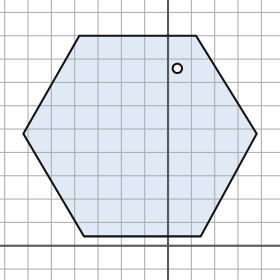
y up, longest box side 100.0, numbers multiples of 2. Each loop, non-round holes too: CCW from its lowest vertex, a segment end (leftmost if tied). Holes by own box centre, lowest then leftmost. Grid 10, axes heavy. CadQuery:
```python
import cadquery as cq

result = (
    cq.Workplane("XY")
    .moveTo(-36.0, 4.0)
    .lineTo(14.0, 4.0)
    .lineTo(38.0, 48.0)
    .lineTo(12.0, 90.0)
    .lineTo(-38.0, 90.0)
    .lineTo(-62.0, 48.0)
    .close()
    .moveTo(4.0, 76.0)
    .circle(2.0)
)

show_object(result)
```